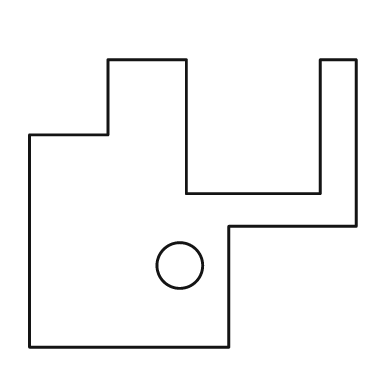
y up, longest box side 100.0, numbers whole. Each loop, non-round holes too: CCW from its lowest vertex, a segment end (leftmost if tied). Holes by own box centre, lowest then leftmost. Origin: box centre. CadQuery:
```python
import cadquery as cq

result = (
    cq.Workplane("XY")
    .moveTo(-50.0, -44.0)
    .lineTo(11.0, -44.0)
    .lineTo(11.0, -7.0)
    .lineTo(50.0, -7.0)
    .lineTo(50.0, 44.0)
    .lineTo(39.0, 44.0)
    .lineTo(39.0, 3.0)
    .lineTo(-2.0, 3.0)
    .lineTo(-2.0, 44.0)
    .lineTo(-26.0, 44.0)
    .lineTo(-26.0, 21.0)
    .lineTo(-50.0, 21.0)
    .close()
    .moveTo(-4.0, -19.0)
    .circle(7.0)
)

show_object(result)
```